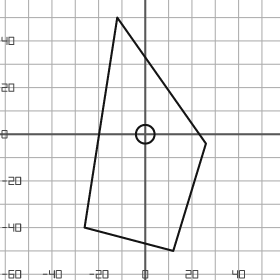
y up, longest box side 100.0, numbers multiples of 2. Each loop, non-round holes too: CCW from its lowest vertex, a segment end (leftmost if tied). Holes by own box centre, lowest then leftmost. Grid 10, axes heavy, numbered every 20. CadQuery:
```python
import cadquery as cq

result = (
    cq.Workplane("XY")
    .moveTo(12.0, -50.0)
    .lineTo(26.0, -4.0)
    .lineTo(-12.0, 50.0)
    .lineTo(-26.0, -40.0)
    .close()
    .moveTo(0.0, 0.0)
    .circle(4.0)
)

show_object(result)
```